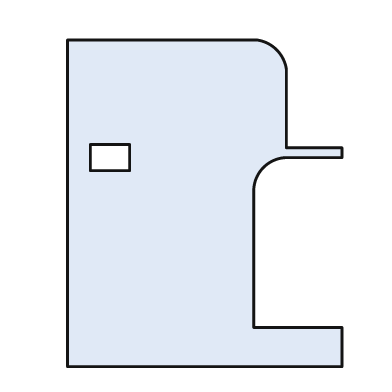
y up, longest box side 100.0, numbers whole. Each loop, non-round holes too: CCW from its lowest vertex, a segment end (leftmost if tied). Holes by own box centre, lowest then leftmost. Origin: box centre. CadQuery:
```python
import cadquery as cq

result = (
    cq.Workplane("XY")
    .moveTo(-42.0, -50.0)
    .lineTo(42.0, -50.0)
    .lineTo(42.0, -38.0)
    .lineTo(15.0, -38.0)
    .lineTo(15.0, 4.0)
    .threePointArc((18.0, 11.0), (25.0, 14.0))
    .lineTo(42.0, 14.0)
    .lineTo(42.0, 17.0)
    .lineTo(25.0, 17.0)
    .lineTo(25.0, 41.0)
    .threePointArc((22.0, 47.0), (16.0, 50.0))
    .lineTo(-42.0, 50.0)
    .close()
    .moveTo(-35.0, 10.0)
    .lineTo(-23.0, 10.0)
    .lineTo(-23.0, 18.0)
    .lineTo(-35.0, 18.0)
    .close()
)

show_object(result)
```